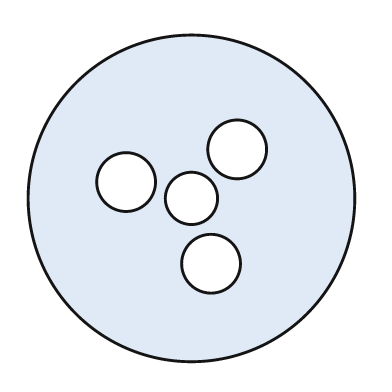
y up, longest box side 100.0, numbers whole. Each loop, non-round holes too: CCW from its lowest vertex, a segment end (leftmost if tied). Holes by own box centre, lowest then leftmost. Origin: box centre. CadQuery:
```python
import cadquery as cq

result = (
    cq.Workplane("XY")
    .moveTo(0.0, 0.0)
    .circle(50.0)
    .moveTo(6.0, -20.0)
    .circle(9.0)
    .moveTo(0.0, 0.0)
    .circle(8.0)
    .moveTo(-20.0, 5.0)
    .circle(9.0)
    .moveTo(14.0, 15.0)
    .circle(9.0)
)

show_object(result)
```